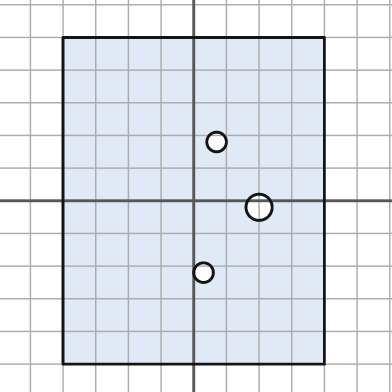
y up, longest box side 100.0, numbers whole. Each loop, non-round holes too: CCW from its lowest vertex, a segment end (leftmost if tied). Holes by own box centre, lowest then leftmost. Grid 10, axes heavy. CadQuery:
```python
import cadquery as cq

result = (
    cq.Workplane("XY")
    .moveTo(-40.0, -50.0)
    .lineTo(40.0, -50.0)
    .lineTo(40.0, 50.0)
    .lineTo(-40.0, 50.0)
    .close()
    .moveTo(3.0, -22.0)
    .circle(3.0)
    .moveTo(20.0, -2.0)
    .circle(4.0)
    .moveTo(7.0, 18.0)
    .circle(3.0)
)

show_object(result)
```